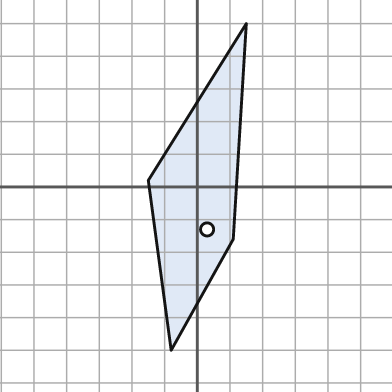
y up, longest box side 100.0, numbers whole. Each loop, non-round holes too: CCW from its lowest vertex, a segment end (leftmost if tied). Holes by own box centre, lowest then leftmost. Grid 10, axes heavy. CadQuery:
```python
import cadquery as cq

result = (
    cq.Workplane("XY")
    .moveTo(-8.0, -50.0)
    .lineTo(11.0, -16.0)
    .lineTo(15.0, 50.0)
    .lineTo(-15.0, 2.0)
    .close()
    .moveTo(3.0, -13.0)
    .circle(2.0)
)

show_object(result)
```